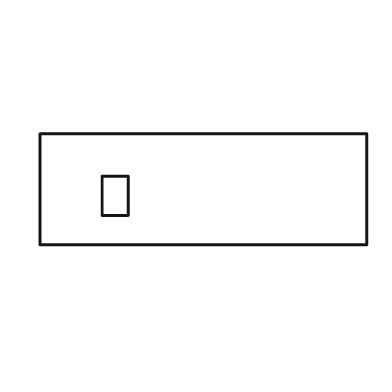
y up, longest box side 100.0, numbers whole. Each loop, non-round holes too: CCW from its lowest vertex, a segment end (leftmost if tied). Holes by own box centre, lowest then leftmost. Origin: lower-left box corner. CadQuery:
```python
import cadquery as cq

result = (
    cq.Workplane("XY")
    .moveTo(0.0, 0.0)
    .lineTo(100.0, 0.0)
    .lineTo(100.0, 34.0)
    .lineTo(0.0, 34.0)
    .close()
    .moveTo(19.0, 9.0)
    .lineTo(27.0, 9.0)
    .lineTo(27.0, 21.0)
    .lineTo(19.0, 21.0)
    .close()
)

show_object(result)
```